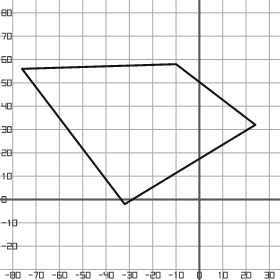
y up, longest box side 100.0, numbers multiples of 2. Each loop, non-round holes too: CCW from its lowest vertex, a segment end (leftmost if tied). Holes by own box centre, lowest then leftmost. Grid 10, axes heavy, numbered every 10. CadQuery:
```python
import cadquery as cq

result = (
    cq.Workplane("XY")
    .moveTo(-32.0, -2.0)
    .lineTo(24.0, 32.0)
    .lineTo(-10.0, 58.0)
    .lineTo(-76.0, 56.0)
    .close()
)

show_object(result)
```